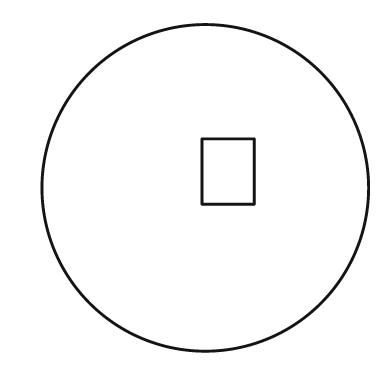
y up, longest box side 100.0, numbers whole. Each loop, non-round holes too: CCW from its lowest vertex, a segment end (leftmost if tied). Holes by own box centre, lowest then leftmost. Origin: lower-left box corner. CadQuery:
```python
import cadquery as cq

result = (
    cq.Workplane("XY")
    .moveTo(50.0, 50.0)
    .circle(50.0)
    .moveTo(49.0, 45.0)
    .lineTo(65.0, 45.0)
    .lineTo(65.0, 65.0)
    .lineTo(49.0, 65.0)
    .close()
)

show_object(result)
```